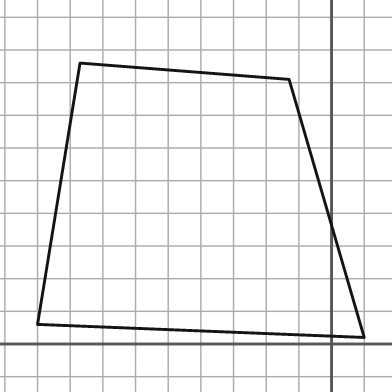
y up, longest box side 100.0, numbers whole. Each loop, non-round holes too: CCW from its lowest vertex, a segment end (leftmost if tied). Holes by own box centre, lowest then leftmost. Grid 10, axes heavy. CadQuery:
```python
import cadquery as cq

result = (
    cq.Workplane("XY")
    .moveTo(10.0, 2.0)
    .lineTo(-13.0, 81.0)
    .lineTo(-77.0, 86.0)
    .lineTo(-90.0, 6.0)
    .close()
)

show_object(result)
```